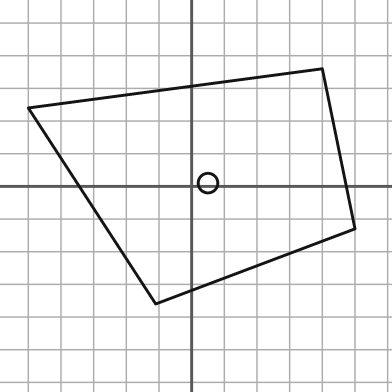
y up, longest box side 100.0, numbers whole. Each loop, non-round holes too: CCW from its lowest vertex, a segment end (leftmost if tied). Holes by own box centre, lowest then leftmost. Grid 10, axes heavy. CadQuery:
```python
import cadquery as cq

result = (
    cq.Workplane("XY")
    .moveTo(-11.0, -36.0)
    .lineTo(50.0, -13.0)
    .lineTo(40.0, 36.0)
    .lineTo(-50.0, 24.0)
    .close()
    .moveTo(5.0, 1.0)
    .circle(3.0)
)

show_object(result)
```